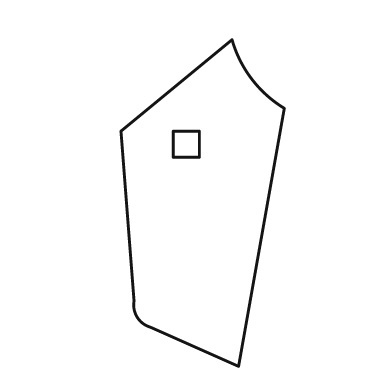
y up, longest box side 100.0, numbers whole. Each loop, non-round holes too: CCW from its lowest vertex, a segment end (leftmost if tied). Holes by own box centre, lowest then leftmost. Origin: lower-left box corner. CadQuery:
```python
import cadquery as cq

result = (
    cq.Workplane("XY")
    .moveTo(36.0, 0.0)
    .lineTo(50.0, 79.0)
    .threePointArc((40.0, 88.0), (34.0, 100.0))
    .lineTo(0.0, 72.0)
    .lineTo(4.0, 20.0)
    .threePointArc((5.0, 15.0), (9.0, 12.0))
    .close()
    .moveTo(16.0, 64.0)
    .lineTo(24.0, 64.0)
    .lineTo(24.0, 72.0)
    .lineTo(16.0, 72.0)
    .close()
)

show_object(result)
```